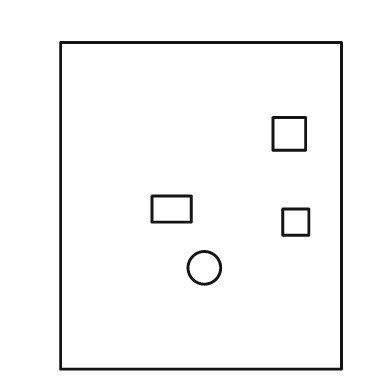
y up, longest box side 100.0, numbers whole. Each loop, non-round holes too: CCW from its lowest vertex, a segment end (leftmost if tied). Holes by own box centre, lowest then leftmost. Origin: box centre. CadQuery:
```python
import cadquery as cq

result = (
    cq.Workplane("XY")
    .moveTo(-43.0, -50.0)
    .lineTo(43.0, -50.0)
    .lineTo(43.0, 50.0)
    .lineTo(-43.0, 50.0)
    .close()
    .moveTo(1.0, -19.0)
    .circle(5.0)
    .moveTo(25.0, -9.0)
    .lineTo(33.0, -9.0)
    .lineTo(33.0, -1.0)
    .lineTo(25.0, -1.0)
    .close()
    .moveTo(-15.0, -5.0)
    .lineTo(-3.0, -5.0)
    .lineTo(-3.0, 3.0)
    .lineTo(-15.0, 3.0)
    .close()
    .moveTo(22.0, 17.0)
    .lineTo(32.0, 17.0)
    .lineTo(32.0, 27.0)
    .lineTo(22.0, 27.0)
    .close()
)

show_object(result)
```